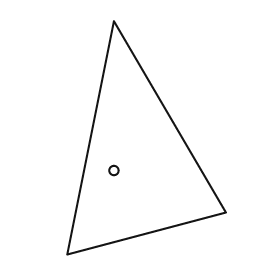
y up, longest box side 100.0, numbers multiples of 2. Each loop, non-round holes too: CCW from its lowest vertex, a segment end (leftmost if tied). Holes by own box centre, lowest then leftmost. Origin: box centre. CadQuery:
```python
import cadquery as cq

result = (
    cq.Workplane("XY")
    .moveTo(-34.0, -50.0)
    .lineTo(34.0, -32.0)
    .lineTo(-14.0, 50.0)
    .close()
    .moveTo(-14.0, -14.0)
    .circle(2.0)
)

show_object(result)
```